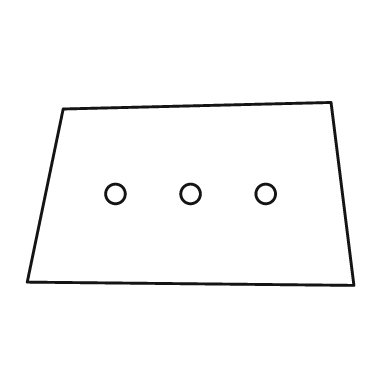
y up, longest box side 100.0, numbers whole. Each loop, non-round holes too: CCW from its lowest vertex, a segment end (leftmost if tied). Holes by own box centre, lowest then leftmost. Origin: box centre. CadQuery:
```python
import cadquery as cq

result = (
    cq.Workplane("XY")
    .moveTo(50.0, -28.0)
    .lineTo(43.0, 28.0)
    .lineTo(-39.0, 26.0)
    .lineTo(-50.0, -27.0)
    .close()
    .moveTo(-23.0, 0.0)
    .circle(3.0)
    .moveTo(0.0, 0.0)
    .circle(3.0)
    .moveTo(23.0, 0.0)
    .circle(3.0)
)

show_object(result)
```